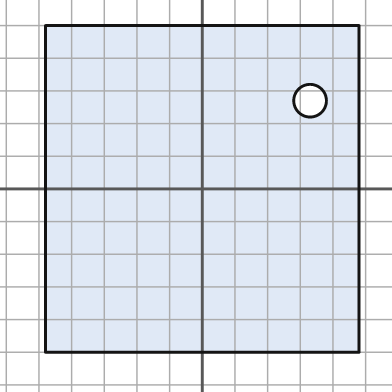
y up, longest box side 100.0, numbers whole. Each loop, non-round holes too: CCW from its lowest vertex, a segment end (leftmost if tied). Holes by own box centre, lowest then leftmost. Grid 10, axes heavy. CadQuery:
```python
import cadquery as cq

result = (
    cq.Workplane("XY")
    .moveTo(-48.0, -50.0)
    .lineTo(48.0, -50.0)
    .lineTo(48.0, 50.0)
    .lineTo(-48.0, 50.0)
    .close()
    .moveTo(33.0, 27.0)
    .circle(5.0)
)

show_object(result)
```